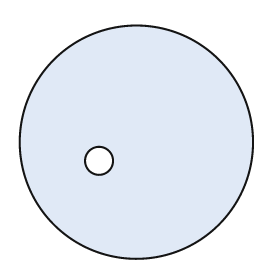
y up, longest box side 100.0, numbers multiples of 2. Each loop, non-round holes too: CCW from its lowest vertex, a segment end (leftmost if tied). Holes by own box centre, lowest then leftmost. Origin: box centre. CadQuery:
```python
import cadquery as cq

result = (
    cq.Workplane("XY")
    .moveTo(0.0, 0.0)
    .circle(50.0)
    .moveTo(-16.0, -8.0)
    .circle(6.0)
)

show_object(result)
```